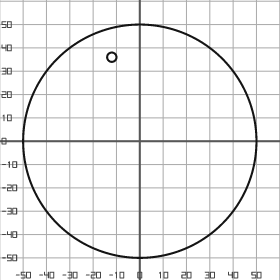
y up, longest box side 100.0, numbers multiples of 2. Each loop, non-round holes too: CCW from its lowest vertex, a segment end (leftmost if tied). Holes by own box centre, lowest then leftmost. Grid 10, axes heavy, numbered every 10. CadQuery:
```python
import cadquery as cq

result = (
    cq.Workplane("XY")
    .moveTo(0.0, 0.0)
    .circle(50.0)
    .moveTo(-12.0, 36.0)
    .circle(2.0)
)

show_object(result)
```